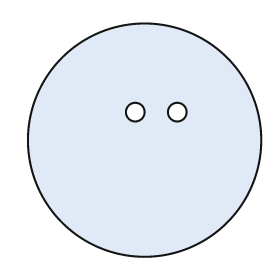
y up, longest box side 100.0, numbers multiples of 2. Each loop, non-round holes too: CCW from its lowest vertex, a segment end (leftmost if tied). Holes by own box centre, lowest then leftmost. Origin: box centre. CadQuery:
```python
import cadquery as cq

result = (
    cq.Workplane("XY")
    .moveTo(0.0, 0.0)
    .circle(50.0)
    .moveTo(-4.0, 12.0)
    .circle(4.0)
    .moveTo(14.0, 12.0)
    .circle(4.0)
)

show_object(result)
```